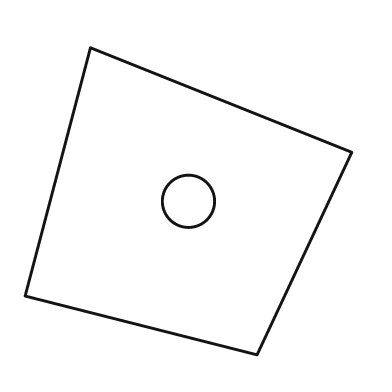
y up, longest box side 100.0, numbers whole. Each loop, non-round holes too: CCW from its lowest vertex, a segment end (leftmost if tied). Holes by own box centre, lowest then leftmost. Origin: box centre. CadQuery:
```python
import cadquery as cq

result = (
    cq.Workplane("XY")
    .moveTo(21.0, -47.0)
    .lineTo(50.0, 15.0)
    .lineTo(-30.0, 47.0)
    .lineTo(-50.0, -29.0)
    .close()
    .moveTo(0.0, 0.0)
    .circle(8.0)
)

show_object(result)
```